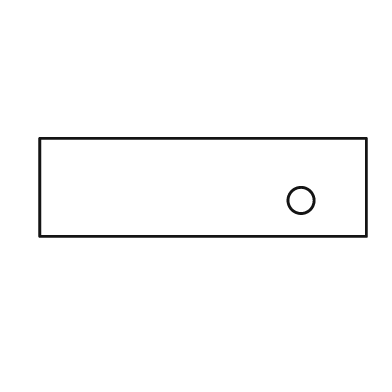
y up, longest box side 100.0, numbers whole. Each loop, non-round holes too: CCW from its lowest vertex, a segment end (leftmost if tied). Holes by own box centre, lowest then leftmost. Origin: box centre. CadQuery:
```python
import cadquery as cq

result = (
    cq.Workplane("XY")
    .moveTo(-50.0, -15.0)
    .lineTo(50.0, -15.0)
    .lineTo(50.0, 15.0)
    .lineTo(-50.0, 15.0)
    .close()
    .moveTo(30.0, -4.0)
    .circle(4.0)
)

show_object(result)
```